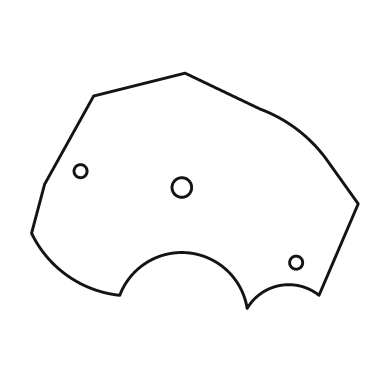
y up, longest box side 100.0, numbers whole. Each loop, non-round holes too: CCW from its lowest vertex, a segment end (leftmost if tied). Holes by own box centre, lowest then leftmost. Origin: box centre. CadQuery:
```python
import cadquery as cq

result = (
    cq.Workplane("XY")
    .moveTo(16.0, -36.0)
    .threePointArc((26.0, -29.0), (38.0, -32.0))
    .lineTo(50.0, -4.0)
    .lineTo(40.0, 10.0)
    .threePointArc((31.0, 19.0), (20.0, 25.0))
    .lineTo(-3.0, 36.0)
    .lineTo(-31.0, 29.0)
    .lineTo(-46.0, 2.0)
    .lineTo(-50.0, -13.0)
    .threePointArc((-39.0, -26.0), (-23.0, -32.0))
    .threePointArc((-2.0, -19.0), (16.0, -36.0))
    .close()
    .moveTo(31.0, -22.0)
    .circle(2.0)
    .moveTo(-4.0, 1.0)
    .circle(3.0)
    .moveTo(-35.0, 6.0)
    .circle(2.0)
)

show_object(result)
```